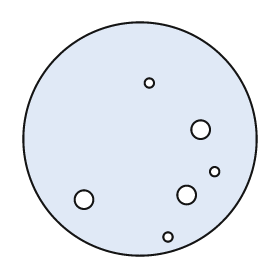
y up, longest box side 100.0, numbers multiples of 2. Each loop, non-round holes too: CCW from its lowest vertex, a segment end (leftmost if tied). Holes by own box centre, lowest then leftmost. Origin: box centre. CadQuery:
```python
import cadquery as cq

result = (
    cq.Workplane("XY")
    .moveTo(0.0, 0.0)
    .circle(50.0)
    .moveTo(12.0, -42.0)
    .circle(2.0)
    .moveTo(-24.0, -26.0)
    .circle(4.0)
    .moveTo(20.0, -24.0)
    .circle(4.0)
    .moveTo(32.0, -14.0)
    .circle(2.0)
    .moveTo(26.0, 4.0)
    .circle(4.0)
    .moveTo(4.0, 24.0)
    .circle(2.0)
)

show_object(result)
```